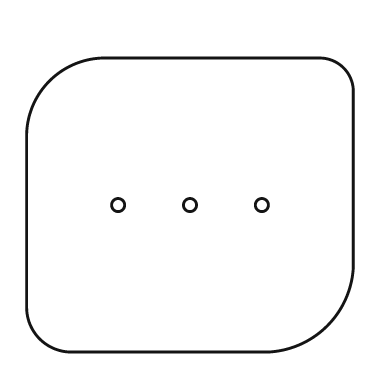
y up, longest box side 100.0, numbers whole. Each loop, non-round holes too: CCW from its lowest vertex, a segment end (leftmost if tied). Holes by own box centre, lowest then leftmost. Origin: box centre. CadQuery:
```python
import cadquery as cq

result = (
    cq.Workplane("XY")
    .moveTo(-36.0, -45.0)
    .lineTo(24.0, -45.0)
    .threePointArc((42.0, -37.0), (50.0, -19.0))
    .lineTo(50.0, 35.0)
    .threePointArc((47.0, 42.0), (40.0, 45.0))
    .lineTo(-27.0, 45.0)
    .threePointArc((-43.0, 38.0), (-50.0, 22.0))
    .lineTo(-50.0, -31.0)
    .threePointArc((-46.0, -41.0), (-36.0, -45.0))
    .close()
    .moveTo(-22.0, 0.0)
    .circle(2.0)
    .moveTo(0.0, 0.0)
    .circle(2.0)
    .moveTo(22.0, 0.0)
    .circle(2.0)
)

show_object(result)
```